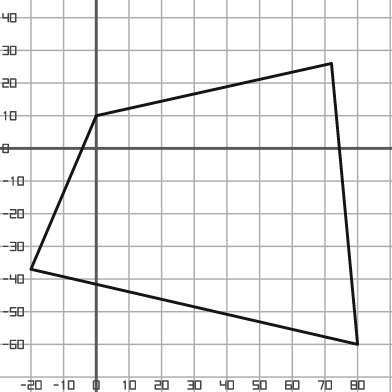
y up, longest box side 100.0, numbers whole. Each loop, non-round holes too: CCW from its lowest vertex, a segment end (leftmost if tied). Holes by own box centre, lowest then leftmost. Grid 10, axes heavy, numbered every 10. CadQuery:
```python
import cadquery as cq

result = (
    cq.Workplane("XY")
    .moveTo(80.0, -60.0)
    .lineTo(72.0, 26.0)
    .lineTo(0.0, 10.0)
    .lineTo(-20.0, -37.0)
    .close()
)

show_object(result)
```